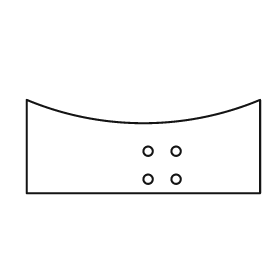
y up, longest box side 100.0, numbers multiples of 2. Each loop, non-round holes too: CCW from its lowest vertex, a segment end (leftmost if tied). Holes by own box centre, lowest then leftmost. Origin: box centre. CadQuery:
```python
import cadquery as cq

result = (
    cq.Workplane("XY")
    .moveTo(-50.0, -20.0)
    .lineTo(50.0, -20.0)
    .lineTo(50.0, 20.0)
    .threePointArc((0.0, 10.0), (-50.0, 20.0))
    .close()
    .moveTo(2.0, -14.0)
    .circle(2.0)
    .moveTo(14.0, -14.0)
    .circle(2.0)
    .moveTo(2.0, -2.0)
    .circle(2.0)
    .moveTo(14.0, -2.0)
    .circle(2.0)
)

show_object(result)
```